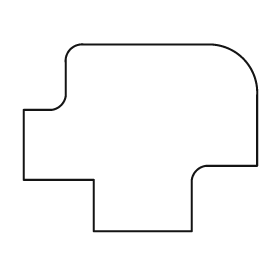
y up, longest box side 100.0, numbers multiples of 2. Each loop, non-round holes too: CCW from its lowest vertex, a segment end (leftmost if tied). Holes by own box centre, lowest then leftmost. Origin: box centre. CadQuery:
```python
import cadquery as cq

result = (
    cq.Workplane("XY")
    .moveTo(-20.0, -40.0)
    .lineTo(22.0, -40.0)
    .lineTo(22.0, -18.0)
    .threePointArc((24.0, -14.0), (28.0, -12.0))
    .lineTo(50.0, -12.0)
    .lineTo(50.0, 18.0)
    .threePointArc((44.0, 34.0), (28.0, 40.0))
    .lineTo(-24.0, 40.0)
    .threePointArc((-30.0, 38.0), (-32.0, 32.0))
    .lineTo(-32.0, 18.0)
    .threePointArc((-34.0, 14.0), (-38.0, 12.0))
    .lineTo(-50.0, 12.0)
    .lineTo(-50.0, -18.0)
    .lineTo(-20.0, -18.0)
    .close()
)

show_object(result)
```